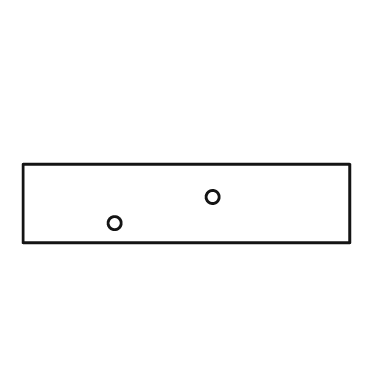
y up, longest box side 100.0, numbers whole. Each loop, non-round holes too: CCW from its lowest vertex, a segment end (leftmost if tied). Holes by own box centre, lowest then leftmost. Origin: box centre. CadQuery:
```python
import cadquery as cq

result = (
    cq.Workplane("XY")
    .moveTo(-50.0, -12.0)
    .lineTo(50.0, -12.0)
    .lineTo(50.0, 12.0)
    .lineTo(-50.0, 12.0)
    .close()
    .moveTo(-22.0, -6.0)
    .circle(2.0)
    .moveTo(8.0, 2.0)
    .circle(2.0)
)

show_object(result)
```